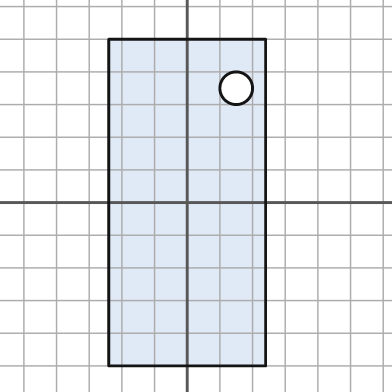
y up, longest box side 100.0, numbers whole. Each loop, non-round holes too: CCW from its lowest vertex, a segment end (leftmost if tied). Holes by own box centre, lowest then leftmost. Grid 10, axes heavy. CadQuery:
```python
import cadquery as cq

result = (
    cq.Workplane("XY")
    .moveTo(-24.0, -50.0)
    .lineTo(24.0, -50.0)
    .lineTo(24.0, 50.0)
    .lineTo(-24.0, 50.0)
    .close()
    .moveTo(15.0, 35.0)
    .circle(5.0)
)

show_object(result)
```